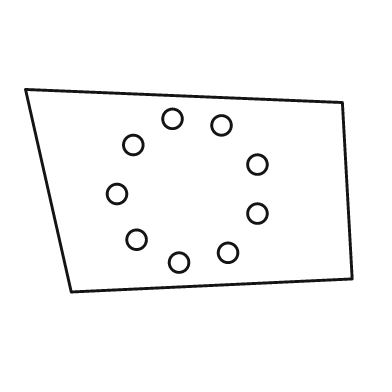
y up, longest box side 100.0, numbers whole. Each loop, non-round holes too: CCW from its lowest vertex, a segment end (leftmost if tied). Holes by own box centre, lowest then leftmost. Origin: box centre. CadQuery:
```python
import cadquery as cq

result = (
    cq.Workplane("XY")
    .moveTo(-36.0, -31.0)
    .lineTo(50.0, -27.0)
    .lineTo(47.0, 27.0)
    .lineTo(-50.0, 31.0)
    .close()
    .moveTo(-3.0, -22.0)
    .circle(3.0)
    .moveTo(12.0, -19.0)
    .circle(3.0)
    .moveTo(-16.0, -15.0)
    .circle(3.0)
    .moveTo(21.0, -7.0)
    .circle(3.0)
    .moveTo(-22.0, -1.0)
    .circle(3.0)
    .moveTo(21.0, 8.0)
    .circle(3.0)
    .moveTo(-17.0, 14.0)
    .circle(3.0)
    .moveTo(10.0, 20.0)
    .circle(3.0)
    .moveTo(-5.0, 22.0)
    .circle(3.0)
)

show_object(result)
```